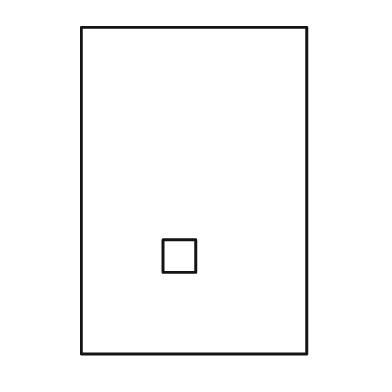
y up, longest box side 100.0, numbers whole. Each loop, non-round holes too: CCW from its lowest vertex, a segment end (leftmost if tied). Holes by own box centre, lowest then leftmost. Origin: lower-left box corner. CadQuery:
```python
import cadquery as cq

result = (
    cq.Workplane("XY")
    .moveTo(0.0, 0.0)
    .lineTo(69.0, 0.0)
    .lineTo(69.0, 100.0)
    .lineTo(0.0, 100.0)
    .close()
    .moveTo(25.0, 25.0)
    .lineTo(35.0, 25.0)
    .lineTo(35.0, 35.0)
    .lineTo(25.0, 35.0)
    .close()
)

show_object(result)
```